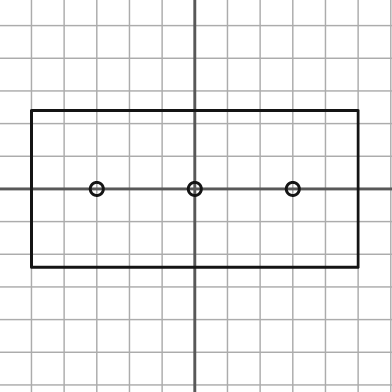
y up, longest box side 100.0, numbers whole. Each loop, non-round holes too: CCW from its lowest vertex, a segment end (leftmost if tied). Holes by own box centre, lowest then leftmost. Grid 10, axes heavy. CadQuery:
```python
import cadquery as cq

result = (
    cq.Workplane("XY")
    .moveTo(-50.0, -24.0)
    .lineTo(50.0, -24.0)
    .lineTo(50.0, 24.0)
    .lineTo(-50.0, 24.0)
    .close()
    .moveTo(-30.0, 0.0)
    .circle(2.0)
    .moveTo(0.0, 0.0)
    .circle(2.0)
    .moveTo(30.0, 0.0)
    .circle(2.0)
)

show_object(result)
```